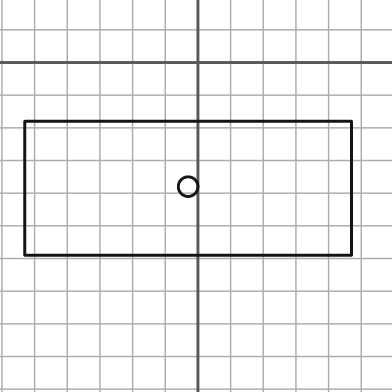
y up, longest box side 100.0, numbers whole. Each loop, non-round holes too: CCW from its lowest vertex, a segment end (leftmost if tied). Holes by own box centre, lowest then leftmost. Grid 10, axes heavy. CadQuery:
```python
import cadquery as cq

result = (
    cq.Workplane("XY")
    .moveTo(-53.0, -59.0)
    .lineTo(47.0, -59.0)
    .lineTo(47.0, -18.0)
    .lineTo(-53.0, -18.0)
    .close()
    .moveTo(-3.0, -38.0)
    .circle(3.0)
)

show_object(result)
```